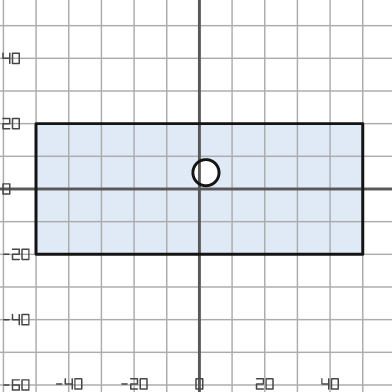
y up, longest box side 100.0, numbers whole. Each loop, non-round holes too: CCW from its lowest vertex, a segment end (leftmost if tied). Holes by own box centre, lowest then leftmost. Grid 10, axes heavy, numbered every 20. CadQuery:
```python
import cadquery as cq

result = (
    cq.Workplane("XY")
    .moveTo(-50.0, -20.0)
    .lineTo(50.0, -20.0)
    .lineTo(50.0, 20.0)
    .lineTo(-50.0, 20.0)
    .close()
    .moveTo(2.0, 5.0)
    .circle(4.0)
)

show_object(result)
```